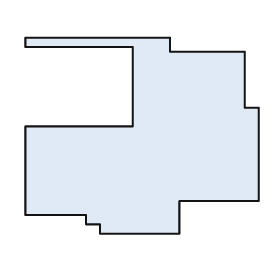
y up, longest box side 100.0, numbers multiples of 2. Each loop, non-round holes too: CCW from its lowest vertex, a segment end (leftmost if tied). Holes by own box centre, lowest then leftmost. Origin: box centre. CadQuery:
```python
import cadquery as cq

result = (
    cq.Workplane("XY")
    .moveTo(-18.0, -42.0)
    .lineTo(16.0, -42.0)
    .lineTo(16.0, -28.0)
    .lineTo(50.0, -28.0)
    .lineTo(50.0, 12.0)
    .lineTo(44.0, 12.0)
    .lineTo(44.0, 36.0)
    .lineTo(12.0, 36.0)
    .lineTo(12.0, 42.0)
    .lineTo(-50.0, 42.0)
    .lineTo(-50.0, 38.0)
    .lineTo(-4.0, 38.0)
    .lineTo(-4.0, 4.0)
    .lineTo(-50.0, 4.0)
    .lineTo(-50.0, -34.0)
    .lineTo(-24.0, -34.0)
    .lineTo(-24.0, -38.0)
    .lineTo(-18.0, -38.0)
    .close()
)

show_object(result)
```